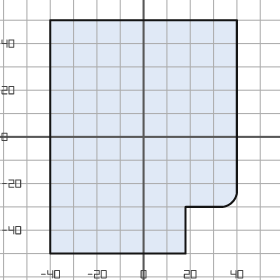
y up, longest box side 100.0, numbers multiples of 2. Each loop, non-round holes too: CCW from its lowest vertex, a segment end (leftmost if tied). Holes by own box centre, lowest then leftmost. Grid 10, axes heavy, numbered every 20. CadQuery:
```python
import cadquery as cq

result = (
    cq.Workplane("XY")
    .moveTo(-40.0, -50.0)
    .lineTo(18.0, -50.0)
    .lineTo(18.0, -30.0)
    .lineTo(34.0, -30.0)
    .threePointArc((38.0, -28.0), (40.0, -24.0))
    .lineTo(40.0, 50.0)
    .lineTo(-40.0, 50.0)
    .close()
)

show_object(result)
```